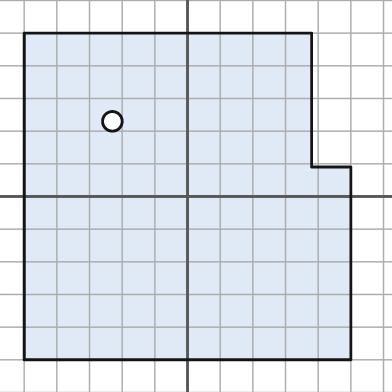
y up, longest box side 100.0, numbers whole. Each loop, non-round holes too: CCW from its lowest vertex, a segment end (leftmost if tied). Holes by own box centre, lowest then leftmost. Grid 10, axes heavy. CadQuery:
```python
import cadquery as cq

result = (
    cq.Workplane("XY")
    .moveTo(-50.0, -50.0)
    .lineTo(50.0, -50.0)
    .lineTo(50.0, 9.0)
    .lineTo(38.0, 9.0)
    .lineTo(38.0, 50.0)
    .lineTo(-50.0, 50.0)
    .close()
    .moveTo(-23.0, 23.0)
    .circle(3.0)
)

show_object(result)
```